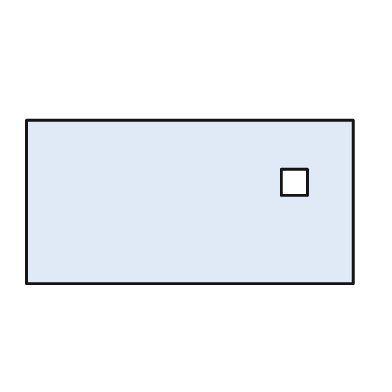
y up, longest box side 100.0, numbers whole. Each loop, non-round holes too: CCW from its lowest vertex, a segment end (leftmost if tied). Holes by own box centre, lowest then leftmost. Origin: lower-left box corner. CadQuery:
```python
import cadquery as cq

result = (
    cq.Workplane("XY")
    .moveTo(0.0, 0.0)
    .lineTo(100.0, 0.0)
    .lineTo(100.0, 50.0)
    .lineTo(0.0, 50.0)
    .close()
    .moveTo(78.0, 27.0)
    .lineTo(86.0, 27.0)
    .lineTo(86.0, 35.0)
    .lineTo(78.0, 35.0)
    .close()
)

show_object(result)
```